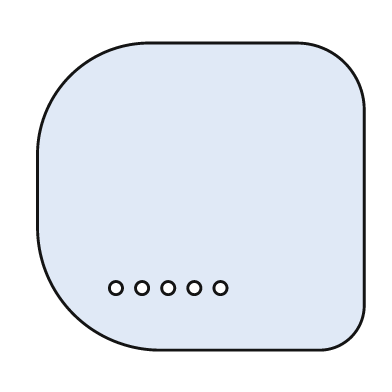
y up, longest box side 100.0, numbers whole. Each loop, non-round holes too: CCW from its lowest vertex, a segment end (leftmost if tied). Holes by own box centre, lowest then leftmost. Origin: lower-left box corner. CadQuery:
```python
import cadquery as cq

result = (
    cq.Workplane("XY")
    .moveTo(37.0, 0.0)
    .lineTo(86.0, 0.0)
    .threePointArc((96.0, 4.0), (100.0, 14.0))
    .lineTo(100.0, 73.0)
    .threePointArc((94.0, 88.0), (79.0, 94.0))
    .lineTo(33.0, 94.0)
    .threePointArc((10.0, 84.0), (0.0, 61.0))
    .lineTo(0.0, 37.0)
    .threePointArc((11.0, 11.0), (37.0, 0.0))
    .close()
    .moveTo(24.0, 19.0)
    .circle(2.0)
    .moveTo(32.0, 19.0)
    .circle(2.0)
    .moveTo(40.0, 19.0)
    .circle(2.0)
    .moveTo(48.0, 19.0)
    .circle(2.0)
    .moveTo(56.0, 19.0)
    .circle(2.0)
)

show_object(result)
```